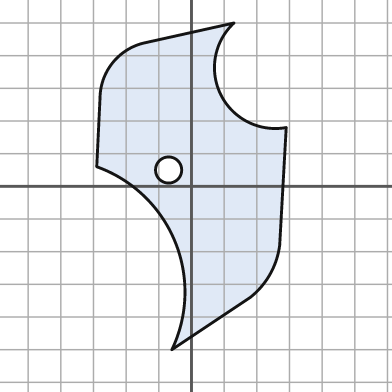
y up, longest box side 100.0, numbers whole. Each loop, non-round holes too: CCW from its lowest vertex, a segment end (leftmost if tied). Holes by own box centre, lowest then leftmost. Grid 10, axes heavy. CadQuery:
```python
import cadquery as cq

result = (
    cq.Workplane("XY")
    .moveTo(-6.0, -50.0)
    .lineTo(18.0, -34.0)
    .threePointArc((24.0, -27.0), (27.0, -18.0))
    .lineTo(29.0, 18.0)
    .threePointArc((9.0, 28.0), (13.0, 50.0))
    .lineTo(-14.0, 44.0)
    .threePointArc((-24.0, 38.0), (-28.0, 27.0))
    .lineTo(-29.0, 6.0)
    .threePointArc((-5.0, -17.0), (-6.0, -50.0))
    .close()
    .moveTo(-7.0, 5.0)
    .circle(4.0)
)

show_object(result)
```